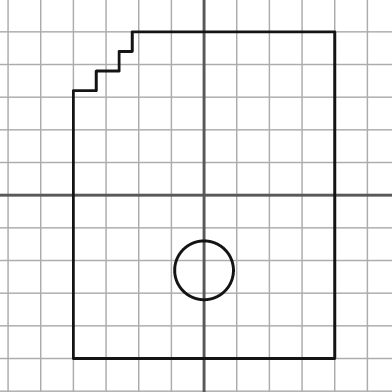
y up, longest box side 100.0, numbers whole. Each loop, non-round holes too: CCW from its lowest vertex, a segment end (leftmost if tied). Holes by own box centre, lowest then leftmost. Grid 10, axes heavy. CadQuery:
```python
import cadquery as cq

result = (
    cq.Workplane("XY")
    .moveTo(-40.0, -50.0)
    .lineTo(40.0, -50.0)
    .lineTo(40.0, 50.0)
    .lineTo(-22.0, 50.0)
    .lineTo(-22.0, 44.0)
    .lineTo(-26.0, 44.0)
    .lineTo(-26.0, 38.0)
    .lineTo(-33.0, 38.0)
    .lineTo(-33.0, 32.0)
    .lineTo(-40.0, 32.0)
    .close()
    .moveTo(0.0, -23.0)
    .circle(9.0)
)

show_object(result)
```